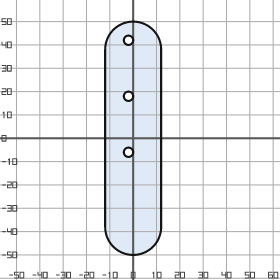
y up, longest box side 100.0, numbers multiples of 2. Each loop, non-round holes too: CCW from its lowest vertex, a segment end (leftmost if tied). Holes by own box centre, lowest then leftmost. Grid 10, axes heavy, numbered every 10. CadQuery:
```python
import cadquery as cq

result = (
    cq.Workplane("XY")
    .moveTo(-12.0, -38.0)
    .threePointArc((0.0, -50.0), (12.0, -38.0))
    .lineTo(12.0, 38.0)
    .threePointArc((0.0, 50.0), (-12.0, 38.0))
    .close()
    .moveTo(-2.0, -6.0)
    .circle(2.0)
    .moveTo(-2.0, 18.0)
    .circle(2.0)
    .moveTo(-2.0, 42.0)
    .circle(2.0)
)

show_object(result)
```